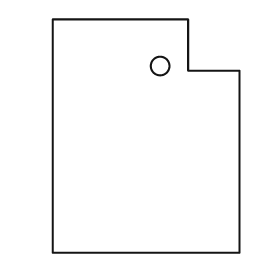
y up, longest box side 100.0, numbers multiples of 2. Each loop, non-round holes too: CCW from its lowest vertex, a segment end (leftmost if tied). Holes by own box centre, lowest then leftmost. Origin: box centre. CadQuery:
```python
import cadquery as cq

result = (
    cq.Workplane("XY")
    .moveTo(-40.0, -50.0)
    .lineTo(40.0, -50.0)
    .lineTo(40.0, 28.0)
    .lineTo(18.0, 28.0)
    .lineTo(18.0, 50.0)
    .lineTo(-40.0, 50.0)
    .close()
    .moveTo(6.0, 30.0)
    .circle(4.0)
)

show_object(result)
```